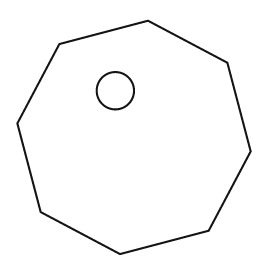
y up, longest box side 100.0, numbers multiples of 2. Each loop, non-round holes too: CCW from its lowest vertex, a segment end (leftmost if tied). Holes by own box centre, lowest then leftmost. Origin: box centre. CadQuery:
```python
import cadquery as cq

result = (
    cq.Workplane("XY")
    .moveTo(-6.0, -50.0)
    .lineTo(32.0, -40.0)
    .lineTo(50.0, -6.0)
    .lineTo(40.0, 32.0)
    .lineTo(6.0, 50.0)
    .lineTo(-32.0, 40.0)
    .lineTo(-50.0, 6.0)
    .lineTo(-40.0, -32.0)
    .close()
    .moveTo(-8.0, 20.0)
    .circle(8.0)
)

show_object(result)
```